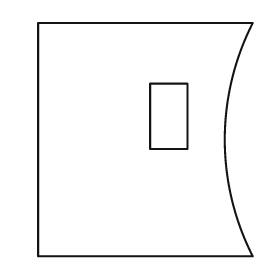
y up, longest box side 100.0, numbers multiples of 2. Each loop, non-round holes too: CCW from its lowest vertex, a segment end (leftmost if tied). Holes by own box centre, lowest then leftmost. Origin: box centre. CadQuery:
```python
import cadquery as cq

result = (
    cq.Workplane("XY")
    .moveTo(-46.0, -50.0)
    .lineTo(46.0, -50.0)
    .threePointArc((34.0, 0.0), (46.0, 50.0))
    .lineTo(-46.0, 50.0)
    .close()
    .moveTo(2.0, -4.0)
    .lineTo(18.0, -4.0)
    .lineTo(18.0, 24.0)
    .lineTo(2.0, 24.0)
    .close()
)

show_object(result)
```